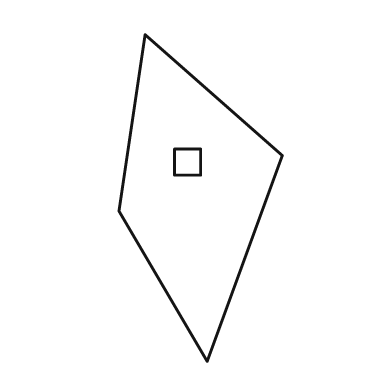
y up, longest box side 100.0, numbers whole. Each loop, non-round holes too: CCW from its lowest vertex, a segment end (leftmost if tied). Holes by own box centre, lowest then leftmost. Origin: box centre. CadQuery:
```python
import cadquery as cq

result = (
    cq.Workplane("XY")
    .moveTo(2.0, -50.0)
    .lineTo(25.0, 13.0)
    .lineTo(-17.0, 50.0)
    .lineTo(-25.0, -4.0)
    .close()
    .moveTo(-8.0, 7.0)
    .lineTo(0.0, 7.0)
    .lineTo(0.0, 15.0)
    .lineTo(-8.0, 15.0)
    .close()
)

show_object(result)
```